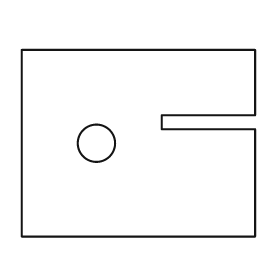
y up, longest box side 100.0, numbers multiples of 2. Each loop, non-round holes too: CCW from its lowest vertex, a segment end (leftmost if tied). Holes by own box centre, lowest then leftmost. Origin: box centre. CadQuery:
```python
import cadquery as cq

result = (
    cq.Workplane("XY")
    .moveTo(-50.0, -40.0)
    .lineTo(50.0, -40.0)
    .lineTo(50.0, 6.0)
    .lineTo(10.0, 6.0)
    .lineTo(10.0, 12.0)
    .lineTo(50.0, 12.0)
    .lineTo(50.0, 40.0)
    .lineTo(-50.0, 40.0)
    .close()
    .moveTo(-18.0, 0.0)
    .circle(8.0)
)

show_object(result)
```